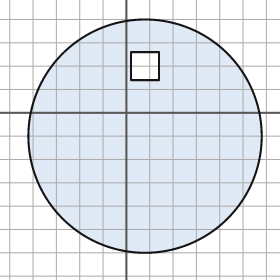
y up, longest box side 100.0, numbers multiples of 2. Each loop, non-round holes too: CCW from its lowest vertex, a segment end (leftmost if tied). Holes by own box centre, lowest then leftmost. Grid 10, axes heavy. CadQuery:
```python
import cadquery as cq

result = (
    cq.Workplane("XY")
    .moveTo(8.0, -10.0)
    .circle(50.0)
    .moveTo(2.0, 14.0)
    .lineTo(14.0, 14.0)
    .lineTo(14.0, 26.0)
    .lineTo(2.0, 26.0)
    .close()
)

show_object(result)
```